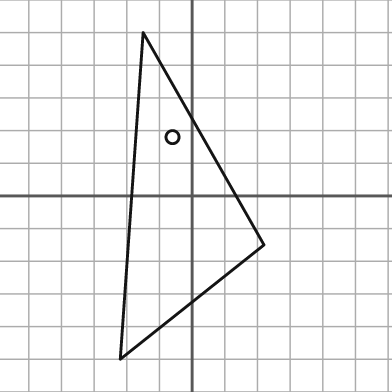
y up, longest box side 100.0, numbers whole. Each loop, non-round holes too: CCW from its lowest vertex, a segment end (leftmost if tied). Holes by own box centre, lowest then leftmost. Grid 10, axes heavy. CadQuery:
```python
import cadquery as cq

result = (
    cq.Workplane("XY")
    .moveTo(-22.0, -50.0)
    .lineTo(22.0, -15.0)
    .lineTo(-15.0, 50.0)
    .close()
    .moveTo(-6.0, 18.0)
    .circle(2.0)
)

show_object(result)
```